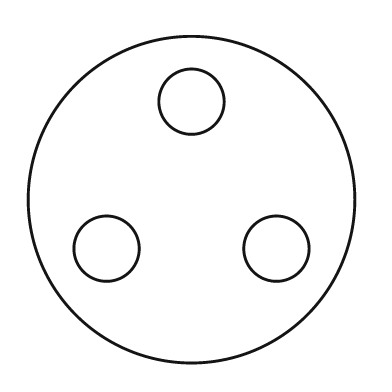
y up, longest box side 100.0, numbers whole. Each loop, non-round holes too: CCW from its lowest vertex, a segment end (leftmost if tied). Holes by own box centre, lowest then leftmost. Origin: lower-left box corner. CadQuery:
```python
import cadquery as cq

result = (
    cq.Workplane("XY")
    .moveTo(50.0, 50.0)
    .circle(50.0)
    .moveTo(24.0, 35.0)
    .circle(10.0)
    .moveTo(76.0, 35.0)
    .circle(10.0)
    .moveTo(50.0, 80.0)
    .circle(10.0)
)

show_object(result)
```